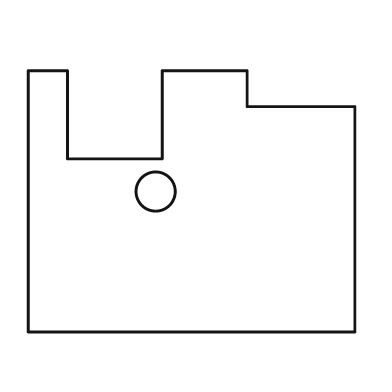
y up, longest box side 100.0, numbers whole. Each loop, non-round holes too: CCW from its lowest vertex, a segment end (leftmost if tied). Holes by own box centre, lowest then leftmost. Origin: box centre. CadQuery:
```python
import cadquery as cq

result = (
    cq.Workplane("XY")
    .moveTo(-50.0, -40.0)
    .lineTo(50.0, -40.0)
    .lineTo(50.0, 29.0)
    .lineTo(17.0, 29.0)
    .lineTo(17.0, 40.0)
    .lineTo(-9.0, 40.0)
    .lineTo(-9.0, 13.0)
    .lineTo(-38.0, 13.0)
    .lineTo(-38.0, 40.0)
    .lineTo(-50.0, 40.0)
    .close()
    .moveTo(-11.0, 3.0)
    .circle(6.0)
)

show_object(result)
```